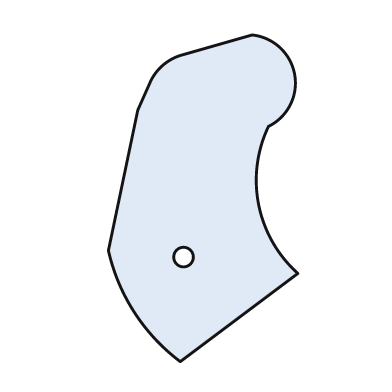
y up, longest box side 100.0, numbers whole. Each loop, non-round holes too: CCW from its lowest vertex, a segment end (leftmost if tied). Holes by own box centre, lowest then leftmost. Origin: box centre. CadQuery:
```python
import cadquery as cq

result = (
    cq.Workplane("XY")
    .moveTo(-7.0, -50.0)
    .lineTo(29.0, -23.0)
    .threePointArc((17.0, -2.0), (20.0, 22.0))
    .threePointArc((28.0, 38.0), (15.0, 50.0))
    .lineTo(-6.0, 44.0)
    .threePointArc((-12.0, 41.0), (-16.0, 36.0))
    .lineTo(-20.0, 27.0)
    .lineTo(-29.0, -16.0)
    .threePointArc((-21.0, -35.0), (-7.0, -50.0))
    .close()
    .moveTo(-6.0, -18.0)
    .circle(3.0)
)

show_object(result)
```